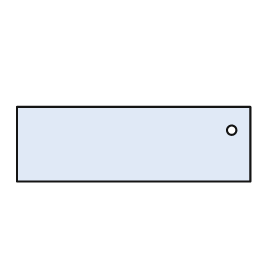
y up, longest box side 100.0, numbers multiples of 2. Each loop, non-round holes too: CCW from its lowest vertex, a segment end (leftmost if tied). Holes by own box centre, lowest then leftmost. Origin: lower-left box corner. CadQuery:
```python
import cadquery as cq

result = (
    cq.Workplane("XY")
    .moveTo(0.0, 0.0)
    .lineTo(100.0, 0.0)
    .lineTo(100.0, 32.0)
    .lineTo(0.0, 32.0)
    .close()
    .moveTo(92.0, 22.0)
    .circle(2.0)
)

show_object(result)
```